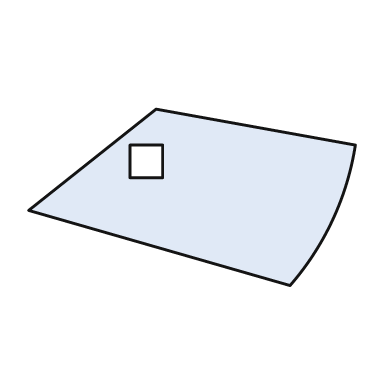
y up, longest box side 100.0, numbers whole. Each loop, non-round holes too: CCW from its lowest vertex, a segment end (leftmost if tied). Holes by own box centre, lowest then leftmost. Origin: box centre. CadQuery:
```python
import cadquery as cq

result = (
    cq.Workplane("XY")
    .moveTo(30.0, -27.0)
    .threePointArc((43.0, -7.0), (50.0, 16.0))
    .lineTo(-11.0, 27.0)
    .lineTo(-50.0, -4.0)
    .close()
    .moveTo(-19.0, 6.0)
    .lineTo(-9.0, 6.0)
    .lineTo(-9.0, 16.0)
    .lineTo(-19.0, 16.0)
    .close()
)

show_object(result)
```